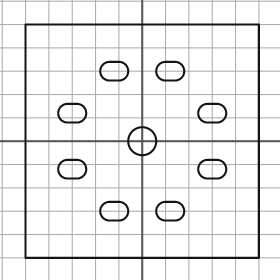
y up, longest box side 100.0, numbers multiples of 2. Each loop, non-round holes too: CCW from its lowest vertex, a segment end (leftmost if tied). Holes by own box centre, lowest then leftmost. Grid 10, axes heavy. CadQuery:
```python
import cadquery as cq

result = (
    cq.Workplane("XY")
    .moveTo(-50.0, -50.0)
    .lineTo(50.0, -50.0)
    .lineTo(50.0, 50.0)
    .lineTo(-50.0, 50.0)
    .close()
    .moveTo(-14.0, -34.0)
    .lineTo(-10.0, -34.0)
    .threePointArc((-6.0, -30.0), (-10.0, -26.0))
    .lineTo(-14.0, -26.0)
    .threePointArc((-18.0, -30.0), (-14.0, -34.0))
    .close()
    .moveTo(10.0, -34.0)
    .lineTo(14.0, -34.0)
    .threePointArc((18.0, -30.0), (14.0, -26.0))
    .lineTo(10.0, -26.0)
    .threePointArc((6.0, -30.0), (10.0, -34.0))
    .close()
    .moveTo(-32.0, -16.0)
    .lineTo(-28.0, -16.0)
    .threePointArc((-24.0, -12.0), (-28.0, -8.0))
    .lineTo(-32.0, -8.0)
    .threePointArc((-36.0, -12.0), (-32.0, -16.0))
    .close()
    .moveTo(28.0, -16.0)
    .lineTo(32.0, -16.0)
    .threePointArc((36.0, -12.0), (32.0, -8.0))
    .lineTo(28.0, -8.0)
    .threePointArc((24.0, -12.0), (28.0, -16.0))
    .close()
    .moveTo(0.0, 0.0)
    .circle(6.0)
    .moveTo(-32.0, 8.0)
    .lineTo(-28.0, 8.0)
    .threePointArc((-24.0, 12.0), (-28.0, 16.0))
    .lineTo(-32.0, 16.0)
    .threePointArc((-36.0, 12.0), (-32.0, 8.0))
    .close()
    .moveTo(28.0, 8.0)
    .lineTo(32.0, 8.0)
    .threePointArc((36.0, 12.0), (32.0, 16.0))
    .lineTo(28.0, 16.0)
    .threePointArc((24.0, 12.0), (28.0, 8.0))
    .close()
    .moveTo(-14.0, 26.0)
    .lineTo(-10.0, 26.0)
    .threePointArc((-6.0, 30.0), (-10.0, 34.0))
    .lineTo(-14.0, 34.0)
    .threePointArc((-18.0, 30.0), (-14.0, 26.0))
    .close()
    .moveTo(10.0, 26.0)
    .lineTo(14.0, 26.0)
    .threePointArc((18.0, 30.0), (14.0, 34.0))
    .lineTo(10.0, 34.0)
    .threePointArc((6.0, 30.0), (10.0, 26.0))
    .close()
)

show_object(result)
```